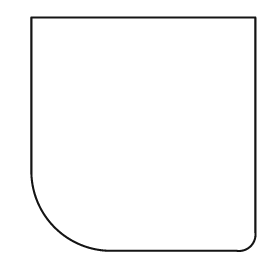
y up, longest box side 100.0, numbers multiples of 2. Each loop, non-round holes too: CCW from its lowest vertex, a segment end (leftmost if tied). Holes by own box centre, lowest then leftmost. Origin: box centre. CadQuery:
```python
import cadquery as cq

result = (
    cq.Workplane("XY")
    .moveTo(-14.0, -50.0)
    .lineTo(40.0, -50.0)
    .threePointArc((46.0, -48.0), (48.0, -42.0))
    .lineTo(48.0, 50.0)
    .lineTo(-48.0, 50.0)
    .lineTo(-48.0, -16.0)
    .threePointArc((-38.0, -40.0), (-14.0, -50.0))
    .close()
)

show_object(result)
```